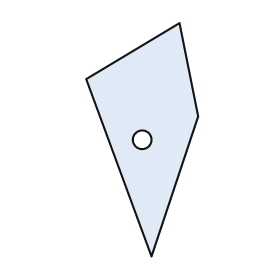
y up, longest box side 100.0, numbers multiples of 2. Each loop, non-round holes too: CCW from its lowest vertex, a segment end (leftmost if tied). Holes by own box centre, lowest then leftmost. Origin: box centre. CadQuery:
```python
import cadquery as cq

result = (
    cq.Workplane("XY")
    .moveTo(4.0, -50.0)
    .lineTo(24.0, 10.0)
    .lineTo(16.0, 50.0)
    .lineTo(-24.0, 26.0)
    .close()
    .moveTo(0.0, 0.0)
    .circle(4.0)
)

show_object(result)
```